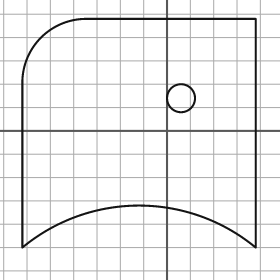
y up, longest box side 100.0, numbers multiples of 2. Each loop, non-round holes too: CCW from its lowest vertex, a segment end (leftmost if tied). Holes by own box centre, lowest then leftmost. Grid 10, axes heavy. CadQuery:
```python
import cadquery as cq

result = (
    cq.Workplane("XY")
    .moveTo(-62.0, -50.0)
    .threePointArc((-12.0, -32.0), (38.0, -50.0))
    .lineTo(38.0, 48.0)
    .lineTo(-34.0, 48.0)
    .threePointArc((-54.0, 40.0), (-62.0, 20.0))
    .close()
    .moveTo(6.0, 14.0)
    .circle(6.0)
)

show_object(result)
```